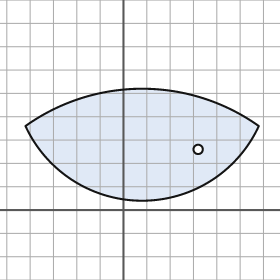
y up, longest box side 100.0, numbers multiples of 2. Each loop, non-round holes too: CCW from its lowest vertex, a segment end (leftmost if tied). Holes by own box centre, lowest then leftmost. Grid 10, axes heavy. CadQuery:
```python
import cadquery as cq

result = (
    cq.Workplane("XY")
    .moveTo(-42.0, 36.0)
    .threePointArc((8.0, 4.0), (58.0, 36.0))
    .threePointArc((8.0, 52.0), (-42.0, 36.0))
    .close()
    .moveTo(32.0, 26.0)
    .circle(2.0)
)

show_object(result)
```